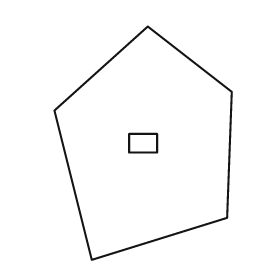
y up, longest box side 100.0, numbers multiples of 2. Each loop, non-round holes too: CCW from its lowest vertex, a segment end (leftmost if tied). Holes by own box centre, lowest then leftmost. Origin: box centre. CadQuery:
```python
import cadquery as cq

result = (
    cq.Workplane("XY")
    .moveTo(-22.0, -50.0)
    .lineTo(36.0, -32.0)
    .lineTo(38.0, 22.0)
    .lineTo(2.0, 50.0)
    .lineTo(-38.0, 14.0)
    .close()
    .moveTo(-6.0, -4.0)
    .lineTo(6.0, -4.0)
    .lineTo(6.0, 4.0)
    .lineTo(-6.0, 4.0)
    .close()
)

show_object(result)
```